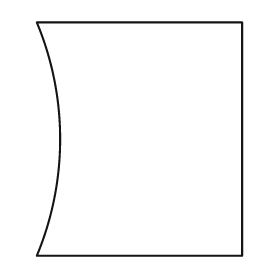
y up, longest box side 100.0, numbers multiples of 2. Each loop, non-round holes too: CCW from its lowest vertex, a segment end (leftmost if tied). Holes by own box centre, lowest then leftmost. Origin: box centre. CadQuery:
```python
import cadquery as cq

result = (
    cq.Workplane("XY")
    .moveTo(-44.0, -50.0)
    .lineTo(44.0, -50.0)
    .lineTo(44.0, 50.0)
    .lineTo(-44.0, 50.0)
    .threePointArc((-34.0, 0.0), (-44.0, -50.0))
    .close()
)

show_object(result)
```